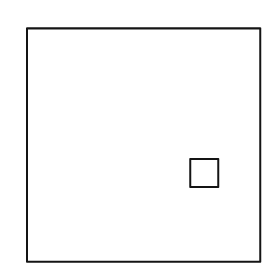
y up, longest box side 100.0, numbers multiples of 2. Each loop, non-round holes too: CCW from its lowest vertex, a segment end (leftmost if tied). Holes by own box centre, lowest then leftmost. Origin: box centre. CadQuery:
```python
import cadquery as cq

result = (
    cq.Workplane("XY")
    .moveTo(-50.0, -50.0)
    .lineTo(50.0, -50.0)
    .lineTo(50.0, 50.0)
    .lineTo(-50.0, 50.0)
    .close()
    .moveTo(20.0, -18.0)
    .lineTo(32.0, -18.0)
    .lineTo(32.0, -6.0)
    .lineTo(20.0, -6.0)
    .close()
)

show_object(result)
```